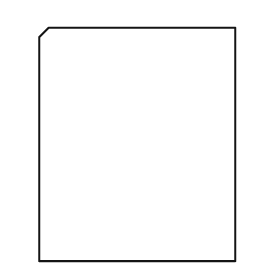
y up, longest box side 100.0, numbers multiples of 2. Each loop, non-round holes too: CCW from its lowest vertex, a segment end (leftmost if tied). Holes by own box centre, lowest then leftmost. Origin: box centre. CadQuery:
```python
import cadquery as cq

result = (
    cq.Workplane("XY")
    .moveTo(-42.0, -50.0)
    .lineTo(42.0, -50.0)
    .lineTo(42.0, 50.0)
    .lineTo(-38.0, 50.0)
    .lineTo(-42.0, 46.0)
    .close()
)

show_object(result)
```